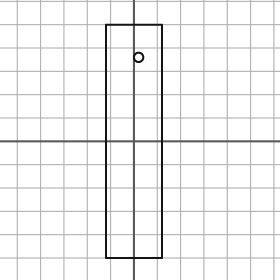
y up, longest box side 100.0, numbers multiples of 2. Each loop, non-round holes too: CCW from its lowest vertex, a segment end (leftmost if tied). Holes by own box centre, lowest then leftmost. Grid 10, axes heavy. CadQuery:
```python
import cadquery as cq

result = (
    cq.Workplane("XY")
    .moveTo(-12.0, -50.0)
    .lineTo(12.0, -50.0)
    .lineTo(12.0, 50.0)
    .lineTo(-12.0, 50.0)
    .close()
    .moveTo(2.0, 36.0)
    .circle(2.0)
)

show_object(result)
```